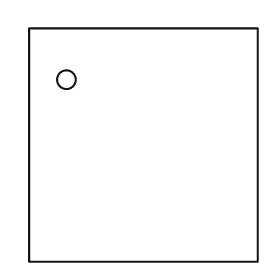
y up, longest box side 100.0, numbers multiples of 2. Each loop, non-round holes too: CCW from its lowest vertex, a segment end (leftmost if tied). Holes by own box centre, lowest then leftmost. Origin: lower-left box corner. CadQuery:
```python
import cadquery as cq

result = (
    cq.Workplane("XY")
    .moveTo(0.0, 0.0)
    .lineTo(98.0, 0.0)
    .lineTo(98.0, 100.0)
    .lineTo(0.0, 100.0)
    .close()
    .moveTo(16.0, 78.0)
    .circle(4.0)
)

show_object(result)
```